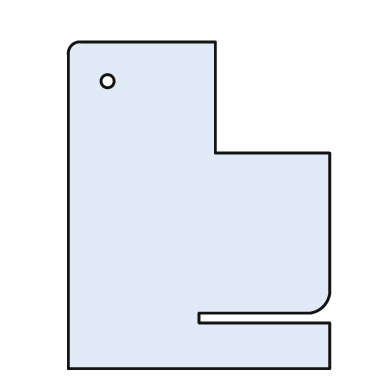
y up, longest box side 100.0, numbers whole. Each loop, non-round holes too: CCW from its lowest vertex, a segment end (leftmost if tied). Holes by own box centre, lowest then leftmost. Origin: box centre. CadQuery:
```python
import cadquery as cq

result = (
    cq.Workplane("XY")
    .moveTo(-40.0, -50.0)
    .lineTo(40.0, -50.0)
    .lineTo(40.0, -36.0)
    .lineTo(0.0, -36.0)
    .lineTo(0.0, -33.0)
    .lineTo(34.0, -33.0)
    .threePointArc((38.0, -31.0), (40.0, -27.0))
    .lineTo(40.0, 16.0)
    .lineTo(5.0, 16.0)
    .lineTo(5.0, 50.0)
    .lineTo(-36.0, 50.0)
    .threePointArc((-39.0, 49.0), (-40.0, 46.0))
    .close()
    .moveTo(-28.0, 38.0)
    .circle(2.0)
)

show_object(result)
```